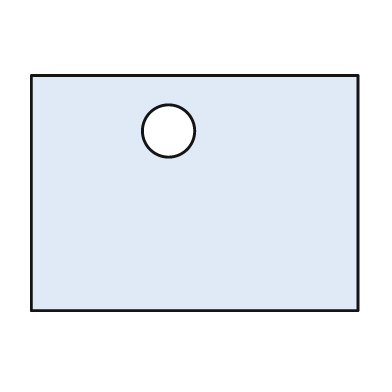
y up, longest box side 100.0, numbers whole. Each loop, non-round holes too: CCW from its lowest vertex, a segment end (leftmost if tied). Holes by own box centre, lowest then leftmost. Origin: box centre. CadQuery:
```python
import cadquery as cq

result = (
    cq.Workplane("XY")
    .moveTo(-50.0, -36.0)
    .lineTo(50.0, -36.0)
    .lineTo(50.0, 36.0)
    .lineTo(-50.0, 36.0)
    .close()
    .moveTo(-8.0, 19.0)
    .circle(8.0)
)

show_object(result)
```